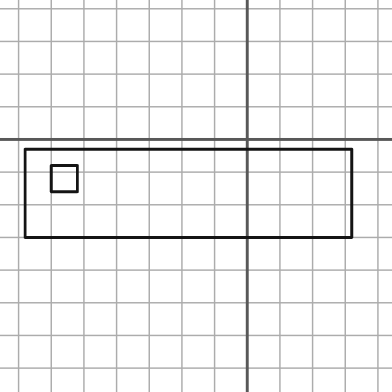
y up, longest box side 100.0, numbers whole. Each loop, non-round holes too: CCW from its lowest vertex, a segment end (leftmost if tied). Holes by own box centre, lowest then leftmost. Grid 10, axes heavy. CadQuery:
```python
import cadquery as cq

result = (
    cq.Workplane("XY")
    .moveTo(-68.0, -30.0)
    .lineTo(32.0, -30.0)
    .lineTo(32.0, -3.0)
    .lineTo(-68.0, -3.0)
    .close()
    .moveTo(-60.0, -16.0)
    .lineTo(-52.0, -16.0)
    .lineTo(-52.0, -8.0)
    .lineTo(-60.0, -8.0)
    .close()
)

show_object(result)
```